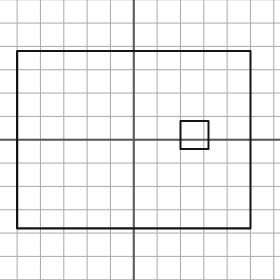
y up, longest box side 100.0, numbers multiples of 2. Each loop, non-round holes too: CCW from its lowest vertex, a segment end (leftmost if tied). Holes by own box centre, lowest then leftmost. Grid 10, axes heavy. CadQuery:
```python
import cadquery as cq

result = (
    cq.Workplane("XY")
    .moveTo(-50.0, -38.0)
    .lineTo(50.0, -38.0)
    .lineTo(50.0, 38.0)
    .lineTo(-50.0, 38.0)
    .close()
    .moveTo(20.0, -4.0)
    .lineTo(32.0, -4.0)
    .lineTo(32.0, 8.0)
    .lineTo(20.0, 8.0)
    .close()
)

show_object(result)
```